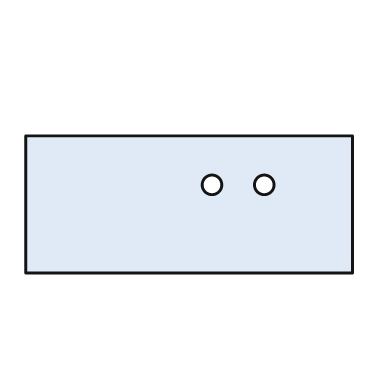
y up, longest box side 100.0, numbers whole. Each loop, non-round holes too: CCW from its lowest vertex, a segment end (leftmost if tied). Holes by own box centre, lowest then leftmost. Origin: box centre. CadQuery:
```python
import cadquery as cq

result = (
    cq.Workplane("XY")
    .moveTo(-50.0, -21.0)
    .lineTo(50.0, -21.0)
    .lineTo(50.0, 21.0)
    .lineTo(-50.0, 21.0)
    .close()
    .moveTo(7.0, 6.0)
    .circle(3.0)
    .moveTo(23.0, 6.0)
    .circle(3.0)
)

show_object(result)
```